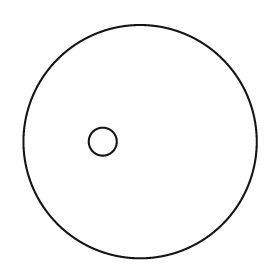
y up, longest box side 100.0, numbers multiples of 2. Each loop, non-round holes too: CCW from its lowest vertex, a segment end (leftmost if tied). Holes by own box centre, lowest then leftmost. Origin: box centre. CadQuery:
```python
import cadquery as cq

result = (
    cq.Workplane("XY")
    .moveTo(0.0, 0.0)
    .circle(50.0)
    .moveTo(-16.0, 0.0)
    .circle(6.0)
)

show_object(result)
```